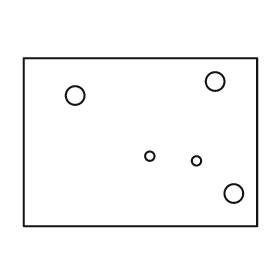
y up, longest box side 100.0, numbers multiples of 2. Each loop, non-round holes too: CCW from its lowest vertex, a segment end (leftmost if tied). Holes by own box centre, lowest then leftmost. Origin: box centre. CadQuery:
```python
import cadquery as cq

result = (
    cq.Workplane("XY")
    .moveTo(-50.0, -36.0)
    .lineTo(50.0, -36.0)
    .lineTo(50.0, 36.0)
    .lineTo(-50.0, 36.0)
    .close()
    .moveTo(40.0, -22.0)
    .circle(4.0)
    .moveTo(24.0, -8.0)
    .circle(2.0)
    .moveTo(4.0, -6.0)
    .circle(2.0)
    .moveTo(-28.0, 20.0)
    .circle(4.0)
    .moveTo(32.0, 26.0)
    .circle(4.0)
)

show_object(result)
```